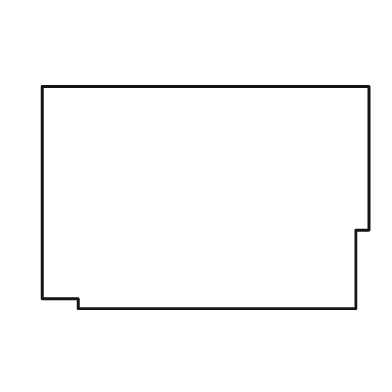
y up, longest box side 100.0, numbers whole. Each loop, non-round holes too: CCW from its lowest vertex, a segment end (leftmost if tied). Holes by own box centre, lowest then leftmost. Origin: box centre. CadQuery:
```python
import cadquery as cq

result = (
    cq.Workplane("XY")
    .moveTo(-39.0, -34.0)
    .lineTo(46.0, -34.0)
    .lineTo(46.0, -10.0)
    .lineTo(50.0, -10.0)
    .lineTo(50.0, 34.0)
    .lineTo(-50.0, 34.0)
    .lineTo(-50.0, -31.0)
    .lineTo(-39.0, -31.0)
    .close()
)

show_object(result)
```